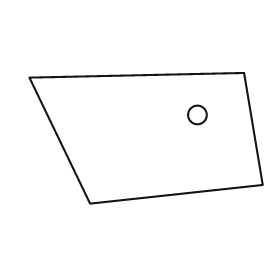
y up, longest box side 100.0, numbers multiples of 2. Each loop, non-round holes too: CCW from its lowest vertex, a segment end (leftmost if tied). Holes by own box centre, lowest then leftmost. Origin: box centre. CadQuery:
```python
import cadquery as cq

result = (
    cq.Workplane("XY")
    .moveTo(-24.0, -28.0)
    .lineTo(50.0, -20.0)
    .lineTo(42.0, 28.0)
    .lineTo(-50.0, 26.0)
    .close()
    .moveTo(22.0, 10.0)
    .circle(4.0)
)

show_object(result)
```